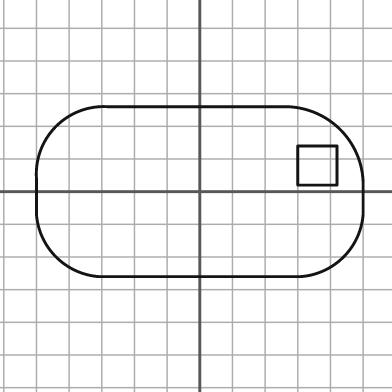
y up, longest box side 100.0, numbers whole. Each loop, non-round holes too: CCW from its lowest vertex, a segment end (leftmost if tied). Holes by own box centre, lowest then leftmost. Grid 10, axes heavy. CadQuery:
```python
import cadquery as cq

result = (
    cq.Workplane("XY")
    .moveTo(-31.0, -26.0)
    .lineTo(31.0, -26.0)
    .threePointArc((44.0, -20.0), (50.0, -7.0))
    .lineTo(50.0, 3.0)
    .threePointArc((43.0, 19.0), (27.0, 26.0))
    .lineTo(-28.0, 26.0)
    .threePointArc((-44.0, 20.0), (-50.0, 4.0))
    .lineTo(-50.0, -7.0)
    .threePointArc((-44.0, -20.0), (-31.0, -26.0))
    .close()
    .moveTo(30.0, 2.0)
    .lineTo(42.0, 2.0)
    .lineTo(42.0, 14.0)
    .lineTo(30.0, 14.0)
    .close()
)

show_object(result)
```